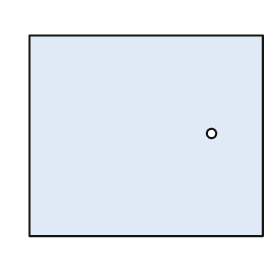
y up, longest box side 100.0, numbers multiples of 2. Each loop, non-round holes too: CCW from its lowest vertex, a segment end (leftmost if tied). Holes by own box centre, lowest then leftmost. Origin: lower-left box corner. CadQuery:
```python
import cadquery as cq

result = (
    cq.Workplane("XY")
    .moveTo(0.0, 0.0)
    .lineTo(100.0, 0.0)
    .lineTo(100.0, 86.0)
    .lineTo(0.0, 86.0)
    .close()
    .moveTo(78.0, 44.0)
    .circle(2.0)
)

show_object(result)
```